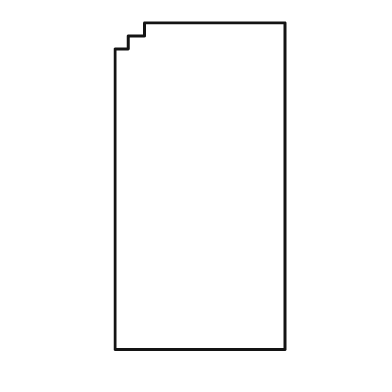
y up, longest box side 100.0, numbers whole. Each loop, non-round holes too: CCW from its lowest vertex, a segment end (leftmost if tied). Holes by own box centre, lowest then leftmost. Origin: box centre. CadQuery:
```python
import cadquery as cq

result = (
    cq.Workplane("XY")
    .moveTo(-26.0, -50.0)
    .lineTo(26.0, -50.0)
    .lineTo(26.0, 50.0)
    .lineTo(-17.0, 50.0)
    .lineTo(-17.0, 46.0)
    .lineTo(-22.0, 46.0)
    .lineTo(-22.0, 42.0)
    .lineTo(-26.0, 42.0)
    .close()
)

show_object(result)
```